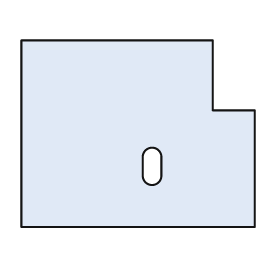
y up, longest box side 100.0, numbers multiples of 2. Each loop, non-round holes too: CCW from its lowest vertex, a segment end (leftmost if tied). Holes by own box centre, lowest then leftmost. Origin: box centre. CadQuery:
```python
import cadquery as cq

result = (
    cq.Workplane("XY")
    .moveTo(-50.0, -40.0)
    .lineTo(50.0, -40.0)
    .lineTo(50.0, 10.0)
    .lineTo(32.0, 10.0)
    .lineTo(32.0, 40.0)
    .lineTo(-50.0, 40.0)
    .close()
    .moveTo(2.0, -18.0)
    .threePointArc((6.0, -22.0), (10.0, -18.0))
    .lineTo(10.0, -10.0)
    .threePointArc((6.0, -6.0), (2.0, -10.0))
    .close()
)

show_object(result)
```